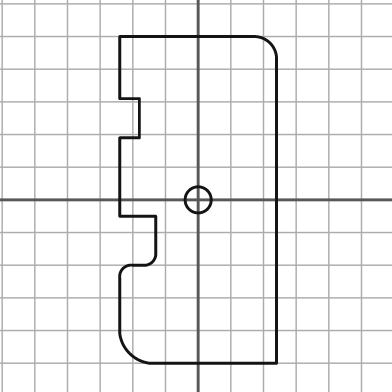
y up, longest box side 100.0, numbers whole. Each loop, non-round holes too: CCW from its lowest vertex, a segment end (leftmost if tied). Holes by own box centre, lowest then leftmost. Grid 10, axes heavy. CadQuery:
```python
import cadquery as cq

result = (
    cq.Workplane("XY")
    .moveTo(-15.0, -50.0)
    .lineTo(24.0, -50.0)
    .lineTo(24.0, 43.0)
    .threePointArc((22.0, 48.0), (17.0, 50.0))
    .lineTo(-24.0, 50.0)
    .lineTo(-24.0, 31.0)
    .lineTo(-18.0, 31.0)
    .lineTo(-18.0, 19.0)
    .lineTo(-24.0, 19.0)
    .lineTo(-24.0, -5.0)
    .lineTo(-13.0, -5.0)
    .lineTo(-13.0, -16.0)
    .threePointArc((-14.0, -19.0), (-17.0, -20.0))
    .lineTo(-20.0, -20.0)
    .threePointArc((-23.0, -21.0), (-24.0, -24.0))
    .lineTo(-24.0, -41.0)
    .threePointArc((-21.0, -47.0), (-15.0, -50.0))
    .close()
    .moveTo(0.0, 0.0)
    .circle(4.0)
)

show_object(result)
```